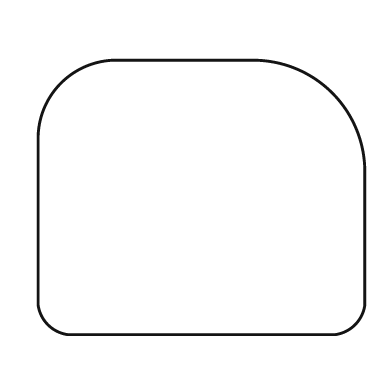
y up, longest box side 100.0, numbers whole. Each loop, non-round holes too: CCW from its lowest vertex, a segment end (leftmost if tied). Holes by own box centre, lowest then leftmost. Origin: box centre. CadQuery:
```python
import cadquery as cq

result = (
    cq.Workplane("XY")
    .moveTo(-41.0, -42.0)
    .lineTo(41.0, -42.0)
    .threePointArc((47.0, -39.0), (50.0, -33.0))
    .lineTo(50.0, 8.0)
    .threePointArc((40.0, 32.0), (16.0, 42.0))
    .lineTo(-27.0, 42.0)
    .threePointArc((-43.0, 35.0), (-50.0, 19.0))
    .lineTo(-50.0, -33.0)
    .threePointArc((-47.0, -39.0), (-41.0, -42.0))
    .close()
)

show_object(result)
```